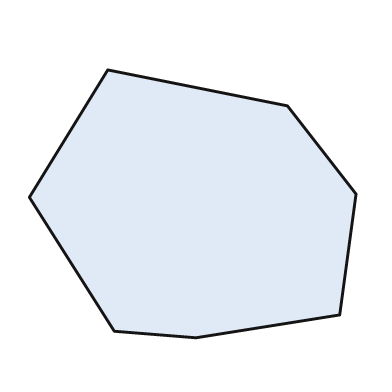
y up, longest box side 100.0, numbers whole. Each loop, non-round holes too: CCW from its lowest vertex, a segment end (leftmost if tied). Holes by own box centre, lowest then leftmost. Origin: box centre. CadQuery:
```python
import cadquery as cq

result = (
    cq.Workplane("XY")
    .moveTo(1.0, -41.0)
    .lineTo(45.0, -34.0)
    .lineTo(50.0, 3.0)
    .lineTo(29.0, 30.0)
    .lineTo(-26.0, 41.0)
    .lineTo(-50.0, 2.0)
    .lineTo(-24.0, -39.0)
    .close()
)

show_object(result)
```